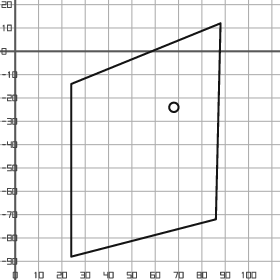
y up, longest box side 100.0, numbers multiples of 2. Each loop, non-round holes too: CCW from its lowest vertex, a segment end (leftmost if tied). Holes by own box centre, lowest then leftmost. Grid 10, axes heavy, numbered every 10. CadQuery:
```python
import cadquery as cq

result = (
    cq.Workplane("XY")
    .moveTo(24.0, -88.0)
    .lineTo(86.0, -72.0)
    .lineTo(88.0, 12.0)
    .lineTo(24.0, -14.0)
    .close()
    .moveTo(68.0, -24.0)
    .circle(2.0)
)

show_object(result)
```